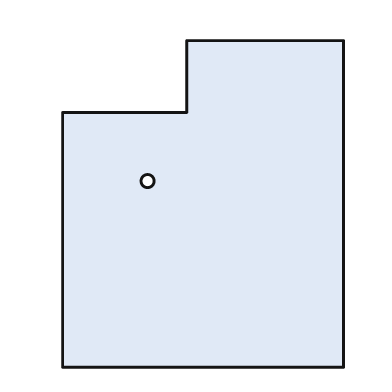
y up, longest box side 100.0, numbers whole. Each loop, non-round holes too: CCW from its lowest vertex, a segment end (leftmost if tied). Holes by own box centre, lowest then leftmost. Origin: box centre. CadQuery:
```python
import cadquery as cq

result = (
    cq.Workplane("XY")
    .moveTo(-43.0, -50.0)
    .lineTo(43.0, -50.0)
    .lineTo(43.0, 50.0)
    .lineTo(-5.0, 50.0)
    .lineTo(-5.0, 28.0)
    .lineTo(-43.0, 28.0)
    .close()
    .moveTo(-17.0, 7.0)
    .circle(2.0)
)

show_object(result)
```